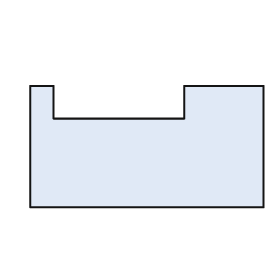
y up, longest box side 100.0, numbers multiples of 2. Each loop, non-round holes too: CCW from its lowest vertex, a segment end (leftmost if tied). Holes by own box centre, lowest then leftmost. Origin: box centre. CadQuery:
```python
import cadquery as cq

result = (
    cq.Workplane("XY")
    .moveTo(-50.0, -26.0)
    .lineTo(50.0, -26.0)
    .lineTo(50.0, 26.0)
    .lineTo(16.0, 26.0)
    .lineTo(16.0, 12.0)
    .lineTo(-40.0, 12.0)
    .lineTo(-40.0, 26.0)
    .lineTo(-50.0, 26.0)
    .close()
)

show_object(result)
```